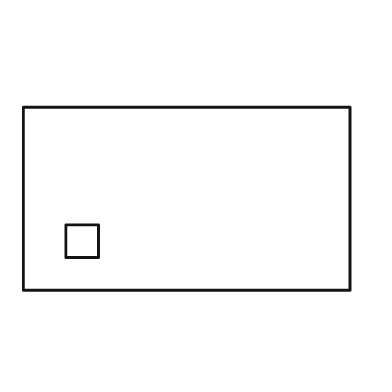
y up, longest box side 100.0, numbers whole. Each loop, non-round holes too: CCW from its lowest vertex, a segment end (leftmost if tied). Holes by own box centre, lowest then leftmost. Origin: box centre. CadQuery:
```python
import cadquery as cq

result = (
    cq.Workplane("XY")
    .moveTo(-50.0, -28.0)
    .lineTo(50.0, -28.0)
    .lineTo(50.0, 28.0)
    .lineTo(-50.0, 28.0)
    .close()
    .moveTo(-37.0, -18.0)
    .lineTo(-27.0, -18.0)
    .lineTo(-27.0, -8.0)
    .lineTo(-37.0, -8.0)
    .close()
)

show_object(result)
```